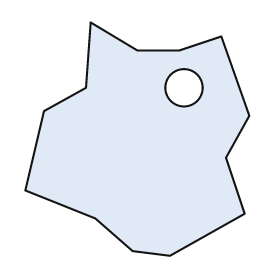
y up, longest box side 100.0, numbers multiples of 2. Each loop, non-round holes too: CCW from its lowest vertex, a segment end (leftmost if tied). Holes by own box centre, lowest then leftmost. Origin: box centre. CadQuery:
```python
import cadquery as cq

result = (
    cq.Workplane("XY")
    .moveTo(14.0, -50.0)
    .lineTo(46.0, -32.0)
    .lineTo(38.0, -8.0)
    .lineTo(48.0, 10.0)
    .lineTo(36.0, 44.0)
    .lineTo(18.0, 38.0)
    .lineTo(0.0, 38.0)
    .lineTo(-20.0, 50.0)
    .lineTo(-22.0, 22.0)
    .lineTo(-40.0, 12.0)
    .lineTo(-48.0, -22.0)
    .lineTo(-18.0, -34.0)
    .lineTo(-2.0, -48.0)
    .close()
    .moveTo(20.0, 22.0)
    .circle(8.0)
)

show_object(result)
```